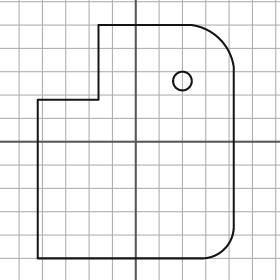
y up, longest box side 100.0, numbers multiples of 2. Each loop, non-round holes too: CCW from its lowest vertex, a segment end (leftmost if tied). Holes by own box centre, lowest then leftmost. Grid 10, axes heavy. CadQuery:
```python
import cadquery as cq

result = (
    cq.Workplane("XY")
    .moveTo(-42.0, -50.0)
    .lineTo(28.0, -50.0)
    .threePointArc((38.0, -46.0), (42.0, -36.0))
    .lineTo(42.0, 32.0)
    .threePointArc((36.0, 44.0), (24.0, 50.0))
    .lineTo(-16.0, 50.0)
    .lineTo(-16.0, 18.0)
    .lineTo(-42.0, 18.0)
    .close()
    .moveTo(20.0, 26.0)
    .circle(4.0)
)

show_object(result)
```